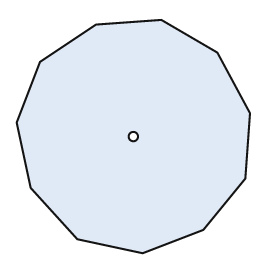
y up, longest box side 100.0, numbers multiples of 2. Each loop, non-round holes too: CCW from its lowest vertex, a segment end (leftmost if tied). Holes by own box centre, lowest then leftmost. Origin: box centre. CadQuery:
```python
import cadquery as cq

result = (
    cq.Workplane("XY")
    .moveTo(4.0, -50.0)
    .lineTo(30.0, -40.0)
    .lineTo(48.0, -18.0)
    .lineTo(50.0, 10.0)
    .lineTo(36.0, 36.0)
    .lineTo(12.0, 50.0)
    .lineTo(-16.0, 48.0)
    .lineTo(-40.0, 32.0)
    .lineTo(-50.0, 6.0)
    .lineTo(-44.0, -22.0)
    .lineTo(-24.0, -44.0)
    .close()
    .moveTo(0.0, 0.0)
    .circle(2.0)
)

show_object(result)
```